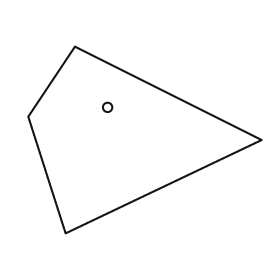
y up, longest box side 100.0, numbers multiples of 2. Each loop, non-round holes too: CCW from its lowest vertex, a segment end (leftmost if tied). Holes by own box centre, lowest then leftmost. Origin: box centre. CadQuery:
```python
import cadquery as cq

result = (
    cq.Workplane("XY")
    .moveTo(-34.0, -40.0)
    .lineTo(50.0, 0.0)
    .lineTo(-30.0, 40.0)
    .lineTo(-50.0, 10.0)
    .close()
    .moveTo(-16.0, 14.0)
    .circle(2.0)
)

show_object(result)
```